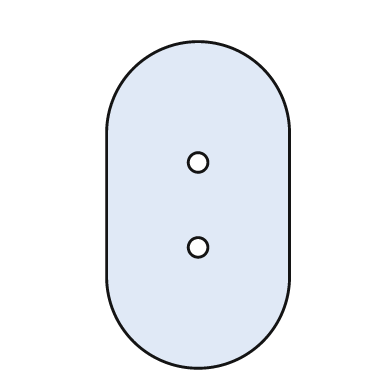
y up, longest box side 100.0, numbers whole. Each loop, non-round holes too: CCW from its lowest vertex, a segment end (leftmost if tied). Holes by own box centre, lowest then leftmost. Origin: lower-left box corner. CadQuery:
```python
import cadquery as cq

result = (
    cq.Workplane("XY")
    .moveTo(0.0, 28.0)
    .threePointArc((28.0, 0.0), (56.0, 28.0))
    .lineTo(56.0, 72.0)
    .threePointArc((28.0, 100.0), (0.0, 72.0))
    .close()
    .moveTo(28.0, 37.0)
    .circle(3.0)
    .moveTo(28.0, 63.0)
    .circle(3.0)
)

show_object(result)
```